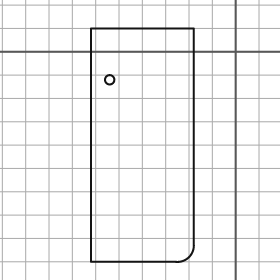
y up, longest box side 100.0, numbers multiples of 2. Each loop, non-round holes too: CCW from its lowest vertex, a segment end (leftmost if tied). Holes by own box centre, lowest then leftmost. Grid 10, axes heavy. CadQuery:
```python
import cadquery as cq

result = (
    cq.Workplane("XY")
    .moveTo(-62.0, -90.0)
    .lineTo(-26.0, -90.0)
    .threePointArc((-20.0, -88.0), (-18.0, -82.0))
    .lineTo(-18.0, 10.0)
    .lineTo(-62.0, 10.0)
    .close()
    .moveTo(-54.0, -12.0)
    .circle(2.0)
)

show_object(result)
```